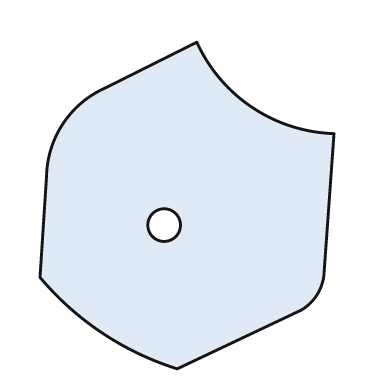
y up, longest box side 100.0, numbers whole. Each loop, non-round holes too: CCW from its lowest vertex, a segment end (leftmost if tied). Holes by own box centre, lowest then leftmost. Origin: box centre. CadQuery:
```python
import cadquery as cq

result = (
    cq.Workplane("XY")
    .moveTo(-3.0, -50.0)
    .lineTo(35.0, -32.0)
    .threePointArc((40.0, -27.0), (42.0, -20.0))
    .lineTo(45.0, 22.0)
    .threePointArc((20.0, 30.0), (3.0, 50.0))
    .lineTo(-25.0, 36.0)
    .threePointArc((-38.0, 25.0), (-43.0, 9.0))
    .lineTo(-45.0, -22.0)
    .threePointArc((-26.0, -39.0), (-3.0, -50.0))
    .close()
    .moveTo(-7.0, -6.0)
    .circle(5.0)
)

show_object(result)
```